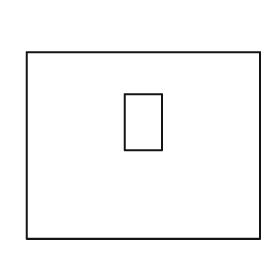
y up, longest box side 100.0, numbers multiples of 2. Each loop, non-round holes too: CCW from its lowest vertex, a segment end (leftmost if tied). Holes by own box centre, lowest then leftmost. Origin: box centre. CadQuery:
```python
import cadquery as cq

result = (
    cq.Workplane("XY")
    .moveTo(-50.0, -40.0)
    .lineTo(50.0, -40.0)
    .lineTo(50.0, 40.0)
    .lineTo(-50.0, 40.0)
    .close()
    .moveTo(-8.0, -2.0)
    .lineTo(8.0, -2.0)
    .lineTo(8.0, 22.0)
    .lineTo(-8.0, 22.0)
    .close()
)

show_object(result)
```